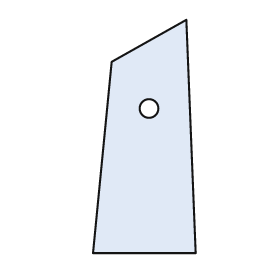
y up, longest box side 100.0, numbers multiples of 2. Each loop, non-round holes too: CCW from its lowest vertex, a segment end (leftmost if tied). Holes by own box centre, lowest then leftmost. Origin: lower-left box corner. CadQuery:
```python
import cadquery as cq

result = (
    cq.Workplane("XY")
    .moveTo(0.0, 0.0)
    .lineTo(44.0, 0.0)
    .lineTo(40.0, 100.0)
    .lineTo(8.0, 82.0)
    .close()
    .moveTo(24.0, 62.0)
    .circle(4.0)
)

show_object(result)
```